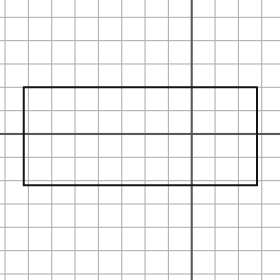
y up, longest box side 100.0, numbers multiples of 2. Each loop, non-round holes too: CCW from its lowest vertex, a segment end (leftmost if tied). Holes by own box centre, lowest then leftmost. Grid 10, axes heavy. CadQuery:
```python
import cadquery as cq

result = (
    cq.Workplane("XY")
    .moveTo(-72.0, -22.0)
    .lineTo(28.0, -22.0)
    .lineTo(28.0, 20.0)
    .lineTo(-72.0, 20.0)
    .close()
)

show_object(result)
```